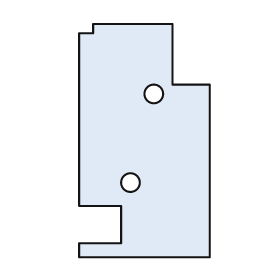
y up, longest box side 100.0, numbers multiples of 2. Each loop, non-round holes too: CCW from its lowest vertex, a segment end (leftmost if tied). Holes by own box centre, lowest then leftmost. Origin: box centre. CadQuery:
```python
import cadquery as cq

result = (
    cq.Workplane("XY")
    .moveTo(-28.0, -50.0)
    .lineTo(28.0, -50.0)
    .lineTo(28.0, 24.0)
    .lineTo(12.0, 24.0)
    .lineTo(12.0, 50.0)
    .lineTo(-22.0, 50.0)
    .lineTo(-22.0, 46.0)
    .lineTo(-28.0, 46.0)
    .lineTo(-28.0, -28.0)
    .lineTo(-10.0, -28.0)
    .lineTo(-10.0, -44.0)
    .lineTo(-28.0, -44.0)
    .close()
    .moveTo(-6.0, -18.0)
    .circle(4.0)
    .moveTo(4.0, 20.0)
    .circle(4.0)
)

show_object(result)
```